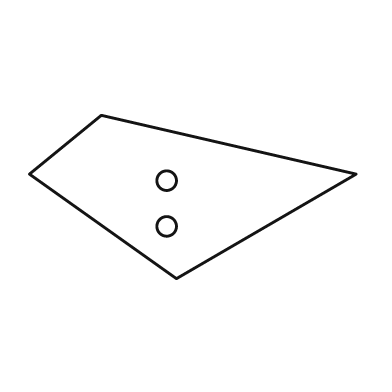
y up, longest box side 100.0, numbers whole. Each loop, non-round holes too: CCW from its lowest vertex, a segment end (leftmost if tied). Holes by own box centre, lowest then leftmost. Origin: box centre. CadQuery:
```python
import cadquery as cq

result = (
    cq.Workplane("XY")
    .moveTo(-5.0, -25.0)
    .lineTo(50.0, 7.0)
    .lineTo(-28.0, 25.0)
    .lineTo(-50.0, 7.0)
    .close()
    .moveTo(-8.0, -9.0)
    .circle(3.0)
    .moveTo(-8.0, 5.0)
    .circle(3.0)
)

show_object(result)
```